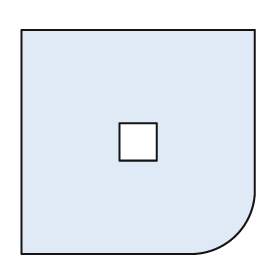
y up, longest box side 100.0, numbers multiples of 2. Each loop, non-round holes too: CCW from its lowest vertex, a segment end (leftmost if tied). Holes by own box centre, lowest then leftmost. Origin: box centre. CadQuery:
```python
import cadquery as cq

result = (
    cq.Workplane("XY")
    .moveTo(-50.0, -48.0)
    .lineTo(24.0, -48.0)
    .threePointArc((42.0, -40.0), (50.0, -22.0))
    .lineTo(50.0, 48.0)
    .lineTo(-50.0, 48.0)
    .close()
    .moveTo(-8.0, -8.0)
    .lineTo(8.0, -8.0)
    .lineTo(8.0, 8.0)
    .lineTo(-8.0, 8.0)
    .close()
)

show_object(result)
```